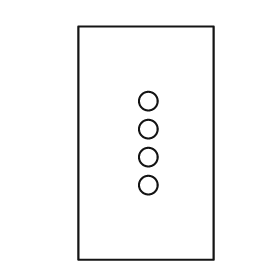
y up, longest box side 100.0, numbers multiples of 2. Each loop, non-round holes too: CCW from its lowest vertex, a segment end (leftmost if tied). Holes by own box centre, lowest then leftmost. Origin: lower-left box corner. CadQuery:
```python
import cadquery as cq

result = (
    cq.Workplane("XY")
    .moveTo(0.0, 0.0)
    .lineTo(58.0, 0.0)
    .lineTo(58.0, 100.0)
    .lineTo(0.0, 100.0)
    .close()
    .moveTo(30.0, 32.0)
    .circle(4.0)
    .moveTo(30.0, 44.0)
    .circle(4.0)
    .moveTo(30.0, 56.0)
    .circle(4.0)
    .moveTo(30.0, 68.0)
    .circle(4.0)
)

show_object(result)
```